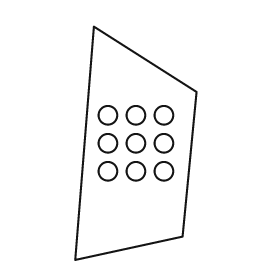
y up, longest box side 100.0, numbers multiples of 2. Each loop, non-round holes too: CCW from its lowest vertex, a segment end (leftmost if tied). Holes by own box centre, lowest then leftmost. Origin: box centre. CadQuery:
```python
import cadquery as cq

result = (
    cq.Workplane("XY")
    .moveTo(-26.0, -50.0)
    .lineTo(20.0, -40.0)
    .lineTo(26.0, 22.0)
    .lineTo(-18.0, 50.0)
    .close()
    .moveTo(-12.0, -12.0)
    .circle(4.0)
    .moveTo(0.0, -12.0)
    .circle(4.0)
    .moveTo(12.0, -12.0)
    .circle(4.0)
    .moveTo(-12.0, 0.0)
    .circle(4.0)
    .moveTo(0.0, 0.0)
    .circle(4.0)
    .moveTo(12.0, 0.0)
    .circle(4.0)
    .moveTo(-12.0, 12.0)
    .circle(4.0)
    .moveTo(0.0, 12.0)
    .circle(4.0)
    .moveTo(12.0, 12.0)
    .circle(4.0)
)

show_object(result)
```